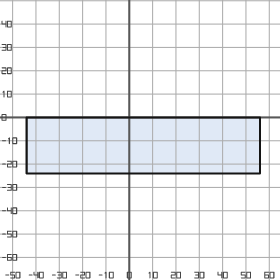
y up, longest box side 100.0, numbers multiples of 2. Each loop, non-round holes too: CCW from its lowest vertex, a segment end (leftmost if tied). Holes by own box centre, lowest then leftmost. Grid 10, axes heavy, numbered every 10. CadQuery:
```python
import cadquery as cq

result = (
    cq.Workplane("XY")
    .moveTo(-44.0, -24.0)
    .lineTo(56.0, -24.0)
    .lineTo(56.0, 0.0)
    .lineTo(-44.0, 0.0)
    .close()
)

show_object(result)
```